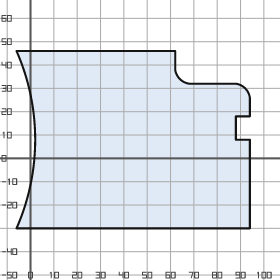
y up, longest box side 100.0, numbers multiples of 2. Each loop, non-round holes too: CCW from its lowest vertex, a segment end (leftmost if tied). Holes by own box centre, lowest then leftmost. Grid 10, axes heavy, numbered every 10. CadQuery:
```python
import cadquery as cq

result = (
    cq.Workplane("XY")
    .moveTo(-6.0, -30.0)
    .lineTo(94.0, -30.0)
    .lineTo(94.0, 8.0)
    .lineTo(88.0, 8.0)
    .lineTo(88.0, 18.0)
    .lineTo(94.0, 18.0)
    .lineTo(94.0, 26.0)
    .threePointArc((92.0, 30.0), (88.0, 32.0))
    .lineTo(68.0, 32.0)
    .threePointArc((64.0, 34.0), (62.0, 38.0))
    .lineTo(62.0, 46.0)
    .lineTo(-6.0, 46.0)
    .threePointArc((2.0, 8.0), (-6.0, -30.0))
    .close()
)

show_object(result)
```